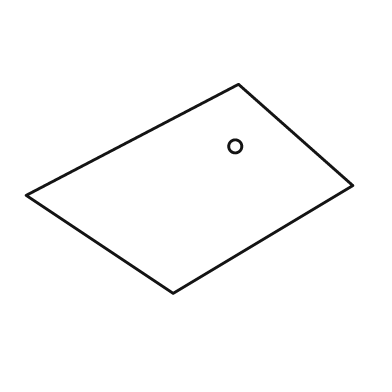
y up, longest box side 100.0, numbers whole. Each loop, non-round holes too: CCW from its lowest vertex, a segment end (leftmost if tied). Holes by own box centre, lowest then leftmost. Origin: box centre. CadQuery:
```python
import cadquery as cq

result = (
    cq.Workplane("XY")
    .moveTo(-5.0, -32.0)
    .lineTo(50.0, 1.0)
    .lineTo(15.0, 32.0)
    .lineTo(-50.0, -2.0)
    .close()
    .moveTo(14.0, 13.0)
    .circle(2.0)
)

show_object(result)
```